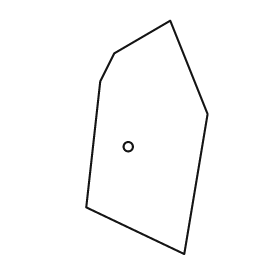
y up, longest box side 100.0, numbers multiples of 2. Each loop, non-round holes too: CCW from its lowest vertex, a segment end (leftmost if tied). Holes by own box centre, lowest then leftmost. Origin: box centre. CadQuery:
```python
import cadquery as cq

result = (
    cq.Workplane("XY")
    .moveTo(16.0, -50.0)
    .lineTo(26.0, 10.0)
    .lineTo(10.0, 50.0)
    .lineTo(-14.0, 36.0)
    .lineTo(-20.0, 24.0)
    .lineTo(-26.0, -30.0)
    .close()
    .moveTo(-8.0, -4.0)
    .circle(2.0)
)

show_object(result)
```